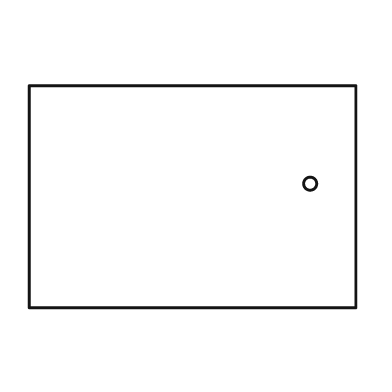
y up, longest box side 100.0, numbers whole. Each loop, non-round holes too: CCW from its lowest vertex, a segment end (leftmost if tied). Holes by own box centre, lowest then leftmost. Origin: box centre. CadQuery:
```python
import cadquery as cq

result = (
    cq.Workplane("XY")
    .moveTo(-50.0, -34.0)
    .lineTo(50.0, -34.0)
    .lineTo(50.0, 34.0)
    .lineTo(-50.0, 34.0)
    .close()
    .moveTo(36.0, 4.0)
    .circle(2.0)
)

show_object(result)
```